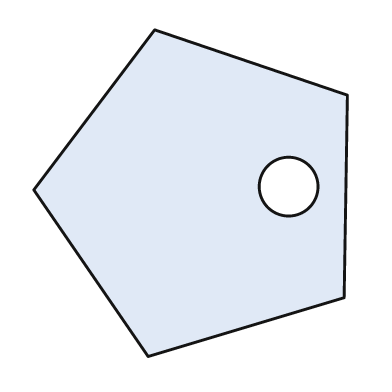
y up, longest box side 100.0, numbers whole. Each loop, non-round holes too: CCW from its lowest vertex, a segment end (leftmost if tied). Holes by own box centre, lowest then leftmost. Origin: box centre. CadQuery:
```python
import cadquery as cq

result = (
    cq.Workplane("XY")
    .moveTo(-13.0, -50.0)
    .lineTo(47.0, -32.0)
    .lineTo(48.0, 30.0)
    .lineTo(-11.0, 50.0)
    .lineTo(-48.0, 1.0)
    .close()
    .moveTo(30.0, 2.0)
    .circle(9.0)
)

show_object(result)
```